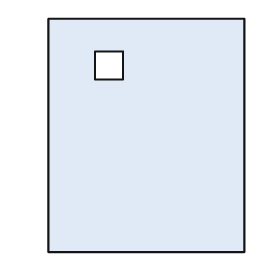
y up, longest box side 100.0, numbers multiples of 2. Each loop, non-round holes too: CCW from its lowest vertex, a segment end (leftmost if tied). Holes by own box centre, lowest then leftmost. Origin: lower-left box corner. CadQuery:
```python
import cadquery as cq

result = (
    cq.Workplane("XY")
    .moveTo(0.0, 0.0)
    .lineTo(84.0, 0.0)
    .lineTo(84.0, 100.0)
    .lineTo(0.0, 100.0)
    .close()
    .moveTo(20.0, 74.0)
    .lineTo(32.0, 74.0)
    .lineTo(32.0, 86.0)
    .lineTo(20.0, 86.0)
    .close()
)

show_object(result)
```